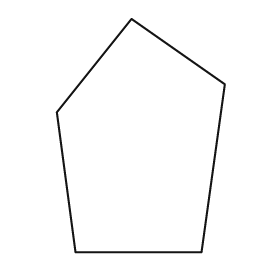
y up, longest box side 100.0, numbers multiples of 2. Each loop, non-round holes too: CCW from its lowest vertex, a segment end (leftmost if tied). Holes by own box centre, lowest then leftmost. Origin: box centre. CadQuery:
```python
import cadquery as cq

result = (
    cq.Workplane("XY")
    .moveTo(-28.0, -50.0)
    .lineTo(26.0, -50.0)
    .lineTo(36.0, 22.0)
    .lineTo(-4.0, 50.0)
    .lineTo(-36.0, 10.0)
    .close()
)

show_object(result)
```